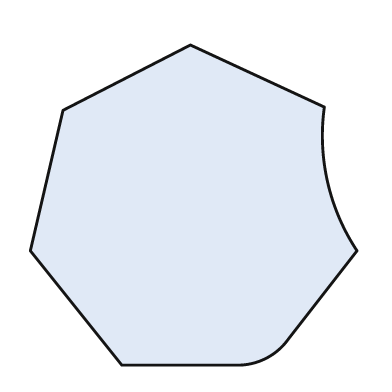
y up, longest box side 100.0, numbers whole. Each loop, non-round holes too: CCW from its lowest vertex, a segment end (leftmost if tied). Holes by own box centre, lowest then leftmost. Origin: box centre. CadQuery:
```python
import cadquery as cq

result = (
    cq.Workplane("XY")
    .moveTo(-22.0, -49.0)
    .lineTo(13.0, -49.0)
    .threePointArc((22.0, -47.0), (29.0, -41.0))
    .lineTo(50.0, -14.0)
    .threePointArc((41.0, 7.0), (40.0, 30.0))
    .lineTo(-1.0, 49.0)
    .lineTo(-40.0, 29.0)
    .lineTo(-50.0, -14.0)
    .close()
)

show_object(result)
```